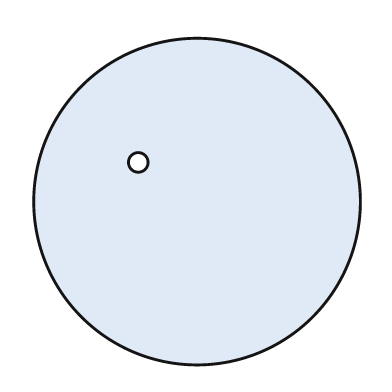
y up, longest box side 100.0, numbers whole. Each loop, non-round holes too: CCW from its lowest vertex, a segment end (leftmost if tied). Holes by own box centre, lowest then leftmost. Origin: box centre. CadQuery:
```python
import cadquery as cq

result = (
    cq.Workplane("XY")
    .moveTo(0.0, 0.0)
    .circle(50.0)
    .moveTo(-18.0, 12.0)
    .circle(3.0)
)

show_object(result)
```